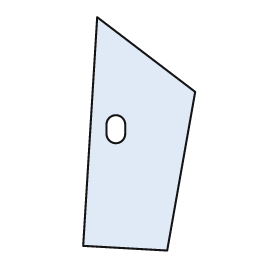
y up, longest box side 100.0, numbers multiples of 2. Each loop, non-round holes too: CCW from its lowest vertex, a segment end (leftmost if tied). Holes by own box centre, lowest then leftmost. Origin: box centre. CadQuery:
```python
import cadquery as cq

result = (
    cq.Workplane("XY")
    .moveTo(12.0, -50.0)
    .lineTo(24.0, 18.0)
    .lineTo(-18.0, 50.0)
    .lineTo(-24.0, -48.0)
    .close()
    .moveTo(-14.0, 0.0)
    .threePointArc((-10.0, -4.0), (-6.0, 0.0))
    .lineTo(-6.0, 4.0)
    .threePointArc((-10.0, 8.0), (-14.0, 4.0))
    .close()
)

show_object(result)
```